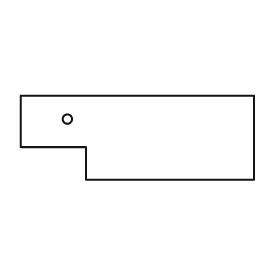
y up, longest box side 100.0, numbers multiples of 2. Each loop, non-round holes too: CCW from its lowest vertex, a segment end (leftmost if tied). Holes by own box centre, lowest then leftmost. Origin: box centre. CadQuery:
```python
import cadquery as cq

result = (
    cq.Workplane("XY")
    .moveTo(-22.0, -18.0)
    .lineTo(50.0, -18.0)
    .lineTo(50.0, 18.0)
    .lineTo(-50.0, 18.0)
    .lineTo(-50.0, -4.0)
    .lineTo(-22.0, -4.0)
    .close()
    .moveTo(-30.0, 8.0)
    .circle(2.0)
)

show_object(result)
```